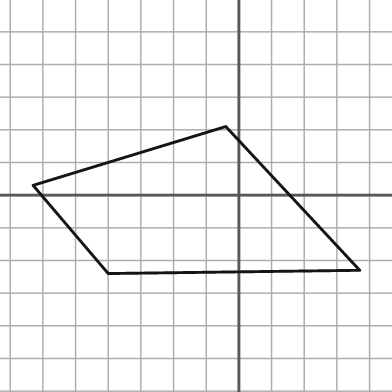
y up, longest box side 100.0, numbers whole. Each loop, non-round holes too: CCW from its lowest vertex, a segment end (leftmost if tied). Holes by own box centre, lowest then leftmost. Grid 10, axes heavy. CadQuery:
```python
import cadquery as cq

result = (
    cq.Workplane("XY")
    .moveTo(-40.0, -24.0)
    .lineTo(37.0, -23.0)
    .lineTo(-4.0, 21.0)
    .lineTo(-63.0, 3.0)
    .close()
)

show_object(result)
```